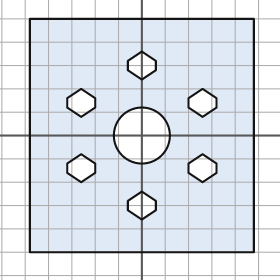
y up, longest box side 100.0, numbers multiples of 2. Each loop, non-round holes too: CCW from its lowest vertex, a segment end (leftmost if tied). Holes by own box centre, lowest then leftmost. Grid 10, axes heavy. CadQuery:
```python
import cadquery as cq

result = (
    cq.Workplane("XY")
    .moveTo(-48.0, -50.0)
    .lineTo(48.0, -50.0)
    .lineTo(48.0, 50.0)
    .lineTo(-48.0, 50.0)
    .close()
    .moveTo(0.0, -36.0)
    .lineTo(6.0, -32.0)
    .lineTo(6.0, -28.0)
    .lineTo(0.0, -24.0)
    .lineTo(-6.0, -28.0)
    .lineTo(-6.0, -32.0)
    .close()
    .moveTo(-26.0, -20.0)
    .lineTo(-20.0, -16.0)
    .lineTo(-20.0, -12.0)
    .lineTo(-26.0, -8.0)
    .lineTo(-32.0, -12.0)
    .lineTo(-32.0, -16.0)
    .close()
    .moveTo(26.0, -20.0)
    .lineTo(32.0, -16.0)
    .lineTo(32.0, -12.0)
    .lineTo(26.0, -8.0)
    .lineTo(20.0, -12.0)
    .lineTo(20.0, -16.0)
    .close()
    .moveTo(0.0, 0.0)
    .circle(12.0)
    .moveTo(-26.0, 8.0)
    .lineTo(-20.0, 12.0)
    .lineTo(-20.0, 16.0)
    .lineTo(-26.0, 20.0)
    .lineTo(-32.0, 16.0)
    .lineTo(-32.0, 12.0)
    .close()
    .moveTo(26.0, 8.0)
    .lineTo(32.0, 12.0)
    .lineTo(32.0, 16.0)
    .lineTo(26.0, 20.0)
    .lineTo(20.0, 16.0)
    .lineTo(20.0, 12.0)
    .close()
    .moveTo(0.0, 24.0)
    .lineTo(6.0, 28.0)
    .lineTo(6.0, 32.0)
    .lineTo(0.0, 36.0)
    .lineTo(-6.0, 32.0)
    .lineTo(-6.0, 28.0)
    .close()
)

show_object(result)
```